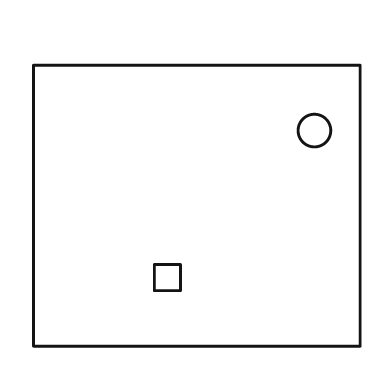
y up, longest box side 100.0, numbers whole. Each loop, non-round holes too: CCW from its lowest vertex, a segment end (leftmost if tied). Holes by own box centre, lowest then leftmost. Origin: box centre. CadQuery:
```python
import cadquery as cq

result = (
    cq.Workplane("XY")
    .moveTo(-50.0, -43.0)
    .lineTo(50.0, -43.0)
    .lineTo(50.0, 43.0)
    .lineTo(-50.0, 43.0)
    .close()
    .moveTo(-13.0, -26.0)
    .lineTo(-5.0, -26.0)
    .lineTo(-5.0, -18.0)
    .lineTo(-13.0, -18.0)
    .close()
    .moveTo(36.0, 23.0)
    .circle(5.0)
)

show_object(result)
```